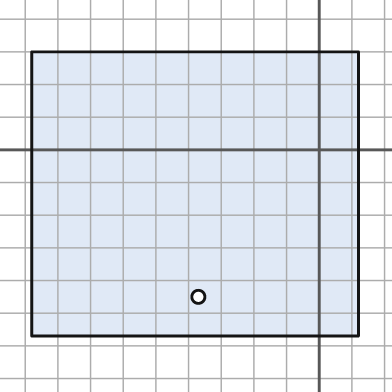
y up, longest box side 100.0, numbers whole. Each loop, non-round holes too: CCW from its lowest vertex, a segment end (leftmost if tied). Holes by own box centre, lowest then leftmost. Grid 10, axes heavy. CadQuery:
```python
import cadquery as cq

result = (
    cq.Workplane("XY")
    .moveTo(-88.0, -57.0)
    .lineTo(12.0, -57.0)
    .lineTo(12.0, 30.0)
    .lineTo(-88.0, 30.0)
    .close()
    .moveTo(-37.0, -45.0)
    .circle(2.0)
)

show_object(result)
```